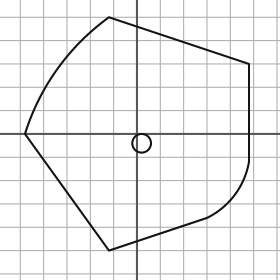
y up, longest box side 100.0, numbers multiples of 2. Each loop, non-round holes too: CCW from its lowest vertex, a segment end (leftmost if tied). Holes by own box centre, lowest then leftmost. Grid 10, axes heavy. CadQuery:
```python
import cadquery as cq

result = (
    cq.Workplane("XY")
    .moveTo(-12.0, -50.0)
    .lineTo(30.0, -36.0)
    .threePointArc((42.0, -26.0), (48.0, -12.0))
    .lineTo(48.0, 30.0)
    .lineTo(-12.0, 50.0)
    .threePointArc((-34.0, 28.0), (-48.0, 0.0))
    .close()
    .moveTo(2.0, -4.0)
    .circle(4.0)
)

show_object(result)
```